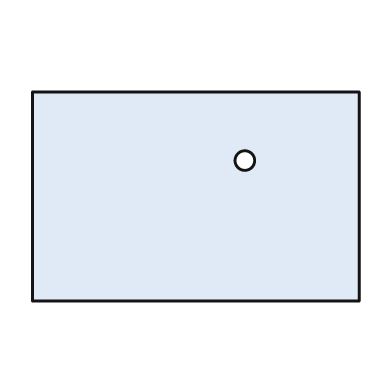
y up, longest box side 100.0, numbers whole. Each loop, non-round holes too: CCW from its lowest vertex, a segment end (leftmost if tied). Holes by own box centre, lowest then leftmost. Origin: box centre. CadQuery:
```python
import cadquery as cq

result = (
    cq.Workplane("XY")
    .moveTo(-50.0, -32.0)
    .lineTo(50.0, -32.0)
    .lineTo(50.0, 32.0)
    .lineTo(-50.0, 32.0)
    .close()
    .moveTo(15.0, 11.0)
    .circle(3.0)
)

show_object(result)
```